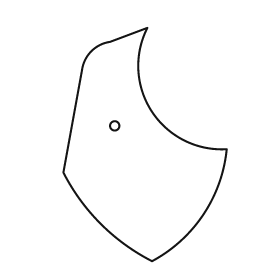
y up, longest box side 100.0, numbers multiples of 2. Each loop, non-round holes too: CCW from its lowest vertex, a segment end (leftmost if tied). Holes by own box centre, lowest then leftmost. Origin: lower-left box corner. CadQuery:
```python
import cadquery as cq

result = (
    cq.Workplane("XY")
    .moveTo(38.0, 0.0)
    .threePointArc((60.0, 20.0), (70.0, 48.0))
    .threePointArc((38.0, 64.0), (36.0, 100.0))
    .lineTo(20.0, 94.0)
    .threePointArc((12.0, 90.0), (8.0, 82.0))
    .lineTo(0.0, 38.0)
    .threePointArc((16.0, 16.0), (38.0, 0.0))
    .close()
    .moveTo(22.0, 58.0)
    .circle(2.0)
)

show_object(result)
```